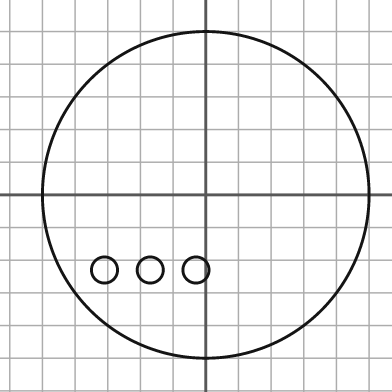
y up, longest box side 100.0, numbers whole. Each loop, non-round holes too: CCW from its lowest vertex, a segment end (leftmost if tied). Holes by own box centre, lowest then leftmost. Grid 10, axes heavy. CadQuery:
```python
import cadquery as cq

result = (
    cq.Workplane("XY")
    .moveTo(0.0, 0.0)
    .circle(50.0)
    .moveTo(-31.0, -23.0)
    .circle(4.0)
    .moveTo(-17.0, -23.0)
    .circle(4.0)
    .moveTo(-3.0, -23.0)
    .circle(4.0)
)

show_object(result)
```